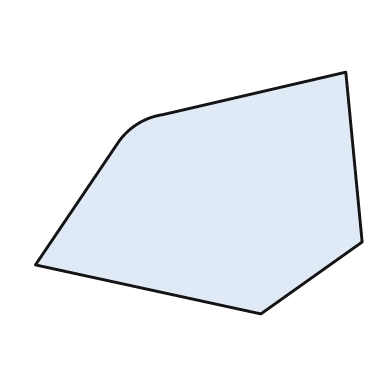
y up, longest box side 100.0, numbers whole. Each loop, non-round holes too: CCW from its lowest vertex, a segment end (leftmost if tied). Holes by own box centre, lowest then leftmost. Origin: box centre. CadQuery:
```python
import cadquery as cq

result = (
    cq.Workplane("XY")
    .moveTo(19.0, -37.0)
    .lineTo(50.0, -15.0)
    .lineTo(45.0, 37.0)
    .lineTo(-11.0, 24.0)
    .threePointArc((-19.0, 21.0), (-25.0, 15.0))
    .lineTo(-50.0, -22.0)
    .close()
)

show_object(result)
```